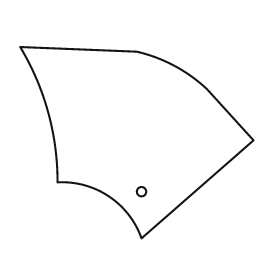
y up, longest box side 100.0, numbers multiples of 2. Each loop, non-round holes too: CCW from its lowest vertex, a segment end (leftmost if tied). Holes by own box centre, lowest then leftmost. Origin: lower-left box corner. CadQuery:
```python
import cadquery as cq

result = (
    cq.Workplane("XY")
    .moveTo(52.0, 0.0)
    .lineTo(100.0, 42.0)
    .lineTo(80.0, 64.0)
    .threePointArc((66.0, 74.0), (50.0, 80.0))
    .lineTo(0.0, 82.0)
    .threePointArc((12.0, 54.0), (16.0, 24.0))
    .threePointArc((38.0, 18.0), (52.0, 0.0))
    .close()
    .moveTo(52.0, 20.0)
    .circle(2.0)
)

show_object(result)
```